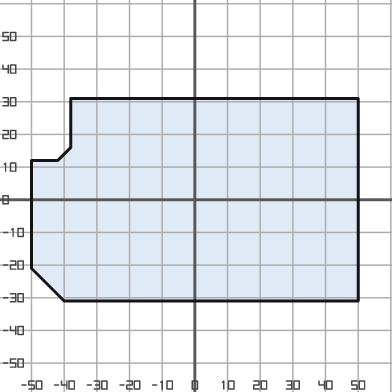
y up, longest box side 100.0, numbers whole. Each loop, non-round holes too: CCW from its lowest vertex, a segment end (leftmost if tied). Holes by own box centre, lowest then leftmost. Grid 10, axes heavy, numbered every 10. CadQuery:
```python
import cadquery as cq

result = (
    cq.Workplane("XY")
    .moveTo(-40.0, -31.0)
    .lineTo(50.0, -31.0)
    .lineTo(50.0, 31.0)
    .lineTo(-38.0, 31.0)
    .lineTo(-38.0, 16.0)
    .lineTo(-42.0, 12.0)
    .lineTo(-50.0, 12.0)
    .lineTo(-50.0, -21.0)
    .close()
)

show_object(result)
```